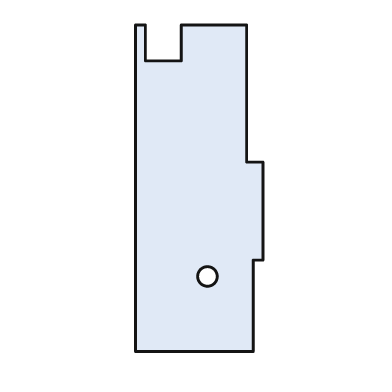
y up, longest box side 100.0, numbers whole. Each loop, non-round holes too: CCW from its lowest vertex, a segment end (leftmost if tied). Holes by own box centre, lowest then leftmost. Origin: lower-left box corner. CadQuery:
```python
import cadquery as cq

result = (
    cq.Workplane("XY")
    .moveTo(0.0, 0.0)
    .lineTo(36.0, 0.0)
    .lineTo(36.0, 28.0)
    .lineTo(39.0, 28.0)
    .lineTo(39.0, 58.0)
    .lineTo(34.0, 58.0)
    .lineTo(34.0, 100.0)
    .lineTo(14.0, 100.0)
    .lineTo(14.0, 89.0)
    .lineTo(3.0, 89.0)
    .lineTo(3.0, 100.0)
    .lineTo(0.0, 100.0)
    .close()
    .moveTo(22.0, 23.0)
    .circle(3.0)
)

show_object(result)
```